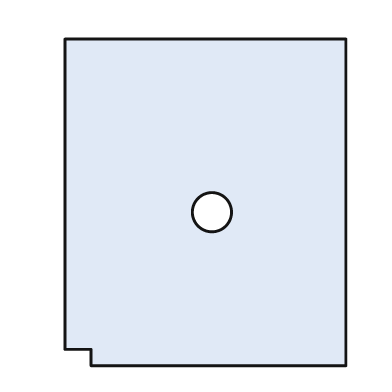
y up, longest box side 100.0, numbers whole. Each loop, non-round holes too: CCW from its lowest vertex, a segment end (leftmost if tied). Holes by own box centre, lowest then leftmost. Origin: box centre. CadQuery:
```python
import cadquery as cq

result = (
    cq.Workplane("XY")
    .moveTo(-35.0, -50.0)
    .lineTo(43.0, -50.0)
    .lineTo(43.0, 50.0)
    .lineTo(-43.0, 50.0)
    .lineTo(-43.0, -45.0)
    .lineTo(-35.0, -45.0)
    .close()
    .moveTo(2.0, -3.0)
    .circle(6.0)
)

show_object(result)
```